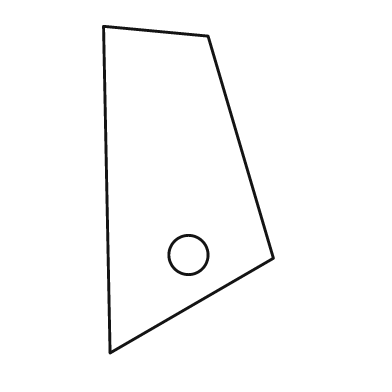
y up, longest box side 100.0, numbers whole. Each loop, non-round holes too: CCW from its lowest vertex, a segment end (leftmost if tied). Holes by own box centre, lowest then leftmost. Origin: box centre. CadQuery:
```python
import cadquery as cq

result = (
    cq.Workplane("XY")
    .moveTo(-24.0, -50.0)
    .lineTo(26.0, -21.0)
    .lineTo(6.0, 47.0)
    .lineTo(-26.0, 50.0)
    .close()
    .moveTo(0.0, -20.0)
    .circle(6.0)
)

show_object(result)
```